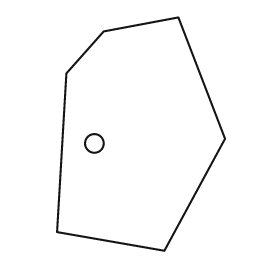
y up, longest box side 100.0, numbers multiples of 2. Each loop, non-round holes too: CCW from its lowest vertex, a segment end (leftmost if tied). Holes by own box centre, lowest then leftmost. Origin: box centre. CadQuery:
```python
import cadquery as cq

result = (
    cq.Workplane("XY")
    .moveTo(10.0, -50.0)
    .lineTo(36.0, -2.0)
    .lineTo(16.0, 50.0)
    .lineTo(-16.0, 44.0)
    .lineTo(-32.0, 26.0)
    .lineTo(-36.0, -42.0)
    .close()
    .moveTo(-20.0, -4.0)
    .circle(4.0)
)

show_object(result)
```